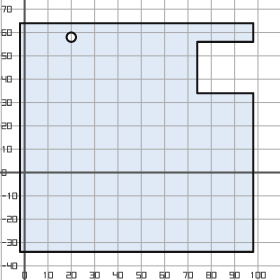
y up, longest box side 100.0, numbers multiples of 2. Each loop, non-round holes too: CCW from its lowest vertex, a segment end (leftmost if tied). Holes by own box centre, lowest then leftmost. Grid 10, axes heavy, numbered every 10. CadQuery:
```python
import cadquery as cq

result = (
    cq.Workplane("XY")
    .moveTo(-2.0, -34.0)
    .lineTo(98.0, -34.0)
    .lineTo(98.0, 34.0)
    .lineTo(74.0, 34.0)
    .lineTo(74.0, 56.0)
    .lineTo(98.0, 56.0)
    .lineTo(98.0, 64.0)
    .lineTo(-2.0, 64.0)
    .close()
    .moveTo(20.0, 58.0)
    .circle(2.0)
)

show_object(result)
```